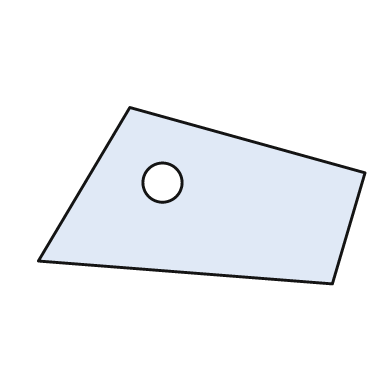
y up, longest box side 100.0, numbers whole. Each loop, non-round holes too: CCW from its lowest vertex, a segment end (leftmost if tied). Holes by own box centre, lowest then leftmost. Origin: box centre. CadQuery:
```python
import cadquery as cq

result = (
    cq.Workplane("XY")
    .moveTo(40.0, -27.0)
    .lineTo(50.0, 7.0)
    .lineTo(-22.0, 27.0)
    .lineTo(-50.0, -20.0)
    .close()
    .moveTo(-12.0, 4.0)
    .circle(6.0)
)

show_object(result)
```